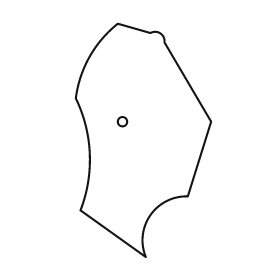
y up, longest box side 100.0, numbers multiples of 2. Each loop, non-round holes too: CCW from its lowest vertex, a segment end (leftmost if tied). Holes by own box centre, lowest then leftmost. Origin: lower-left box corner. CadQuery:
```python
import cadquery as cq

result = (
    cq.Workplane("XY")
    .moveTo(30.0, 0.0)
    .threePointArc((32.0, 18.0), (48.0, 26.0))
    .lineTo(58.0, 58.0)
    .lineTo(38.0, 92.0)
    .threePointArc((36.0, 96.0), (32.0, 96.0))
    .lineTo(18.0, 100.0)
    .threePointArc((6.0, 86.0), (0.0, 68.0))
    .threePointArc((6.0, 44.0), (2.0, 20.0))
    .close()
    .moveTo(20.0, 58.0)
    .circle(2.0)
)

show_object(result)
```